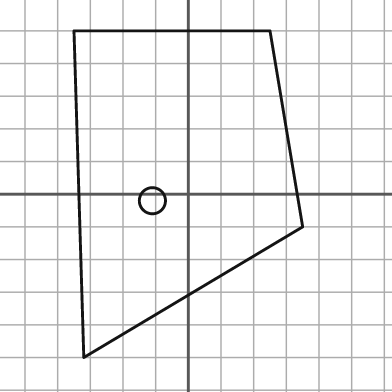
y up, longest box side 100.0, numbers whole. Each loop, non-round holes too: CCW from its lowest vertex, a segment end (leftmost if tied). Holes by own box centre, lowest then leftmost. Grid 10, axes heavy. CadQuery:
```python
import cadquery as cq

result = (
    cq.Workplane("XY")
    .moveTo(-32.0, -50.0)
    .lineTo(35.0, -10.0)
    .lineTo(25.0, 50.0)
    .lineTo(-35.0, 50.0)
    .close()
    .moveTo(-11.0, -2.0)
    .circle(4.0)
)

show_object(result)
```